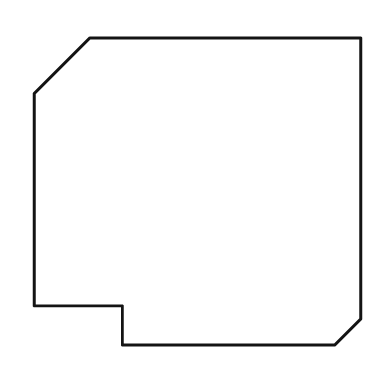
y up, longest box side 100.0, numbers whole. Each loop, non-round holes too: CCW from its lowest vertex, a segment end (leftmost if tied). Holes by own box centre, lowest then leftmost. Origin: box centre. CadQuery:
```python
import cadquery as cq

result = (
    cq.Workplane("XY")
    .moveTo(-23.0, -47.0)
    .lineTo(42.0, -47.0)
    .lineTo(50.0, -39.0)
    .lineTo(50.0, 47.0)
    .lineTo(-33.0, 47.0)
    .lineTo(-50.0, 30.0)
    .lineTo(-50.0, -35.0)
    .lineTo(-23.0, -35.0)
    .close()
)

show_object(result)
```